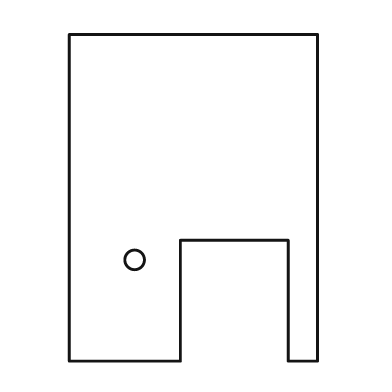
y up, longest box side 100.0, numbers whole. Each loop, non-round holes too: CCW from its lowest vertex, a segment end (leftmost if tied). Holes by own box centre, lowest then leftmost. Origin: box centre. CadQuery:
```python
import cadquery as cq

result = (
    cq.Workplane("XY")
    .moveTo(-38.0, -50.0)
    .lineTo(-4.0, -50.0)
    .lineTo(-4.0, -13.0)
    .lineTo(29.0, -13.0)
    .lineTo(29.0, -50.0)
    .lineTo(38.0, -50.0)
    .lineTo(38.0, 50.0)
    .lineTo(-38.0, 50.0)
    .close()
    .moveTo(-18.0, -19.0)
    .circle(3.0)
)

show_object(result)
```